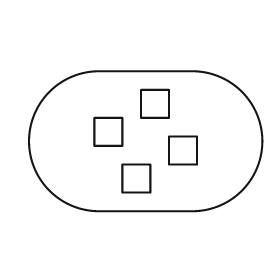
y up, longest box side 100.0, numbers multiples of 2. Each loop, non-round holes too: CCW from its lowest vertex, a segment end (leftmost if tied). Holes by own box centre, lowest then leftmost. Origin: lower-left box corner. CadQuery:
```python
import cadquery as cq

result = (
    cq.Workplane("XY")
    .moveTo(30.0, 0.0)
    .lineTo(70.0, 0.0)
    .threePointArc((100.0, 30.0), (70.0, 60.0))
    .lineTo(30.0, 60.0)
    .threePointArc((0.0, 30.0), (30.0, 0.0))
    .close()
    .moveTo(40.0, 8.0)
    .lineTo(52.0, 8.0)
    .lineTo(52.0, 20.0)
    .lineTo(40.0, 20.0)
    .close()
    .moveTo(60.0, 20.0)
    .lineTo(72.0, 20.0)
    .lineTo(72.0, 32.0)
    .lineTo(60.0, 32.0)
    .close()
    .moveTo(28.0, 28.0)
    .lineTo(40.0, 28.0)
    .lineTo(40.0, 40.0)
    .lineTo(28.0, 40.0)
    .close()
    .moveTo(48.0, 40.0)
    .lineTo(60.0, 40.0)
    .lineTo(60.0, 52.0)
    .lineTo(48.0, 52.0)
    .close()
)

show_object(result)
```